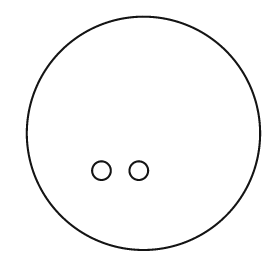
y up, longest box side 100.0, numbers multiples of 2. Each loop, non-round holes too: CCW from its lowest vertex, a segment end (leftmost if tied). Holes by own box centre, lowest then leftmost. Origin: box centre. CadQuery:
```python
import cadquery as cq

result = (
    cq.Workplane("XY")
    .moveTo(0.0, 0.0)
    .circle(50.0)
    .moveTo(-18.0, -16.0)
    .circle(4.0)
    .moveTo(-2.0, -16.0)
    .circle(4.0)
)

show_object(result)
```